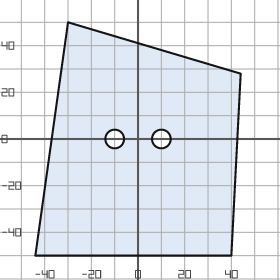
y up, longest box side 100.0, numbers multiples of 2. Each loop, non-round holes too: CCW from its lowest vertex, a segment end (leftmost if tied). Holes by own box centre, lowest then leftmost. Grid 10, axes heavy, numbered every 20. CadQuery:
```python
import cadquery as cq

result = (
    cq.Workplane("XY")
    .moveTo(-44.0, -50.0)
    .lineTo(40.0, -50.0)
    .lineTo(44.0, 28.0)
    .lineTo(-30.0, 50.0)
    .close()
    .moveTo(-10.0, 0.0)
    .circle(4.0)
    .moveTo(10.0, 0.0)
    .circle(4.0)
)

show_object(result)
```